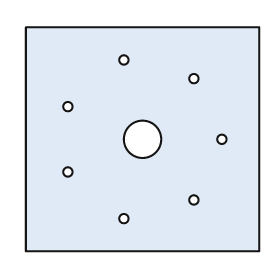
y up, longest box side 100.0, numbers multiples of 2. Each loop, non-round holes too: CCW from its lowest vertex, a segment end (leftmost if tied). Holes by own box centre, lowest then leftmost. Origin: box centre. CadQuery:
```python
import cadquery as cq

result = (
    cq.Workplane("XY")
    .moveTo(-50.0, -48.0)
    .lineTo(50.0, -48.0)
    .lineTo(50.0, 48.0)
    .lineTo(-50.0, 48.0)
    .close()
    .moveTo(-8.0, -34.0)
    .circle(2.0)
    .moveTo(22.0, -26.0)
    .circle(2.0)
    .moveTo(-32.0, -14.0)
    .circle(2.0)
    .moveTo(0.0, 0.0)
    .circle(8.0)
    .moveTo(34.0, 0.0)
    .circle(2.0)
    .moveTo(-32.0, 14.0)
    .circle(2.0)
    .moveTo(22.0, 26.0)
    .circle(2.0)
    .moveTo(-8.0, 34.0)
    .circle(2.0)
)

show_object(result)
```